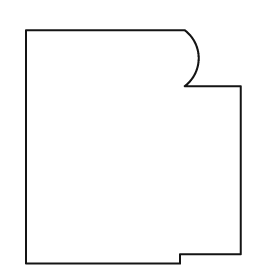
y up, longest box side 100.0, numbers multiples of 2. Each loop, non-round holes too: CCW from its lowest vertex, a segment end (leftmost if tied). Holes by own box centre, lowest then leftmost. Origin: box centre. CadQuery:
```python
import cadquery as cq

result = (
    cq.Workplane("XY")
    .moveTo(-46.0, -50.0)
    .lineTo(20.0, -50.0)
    .lineTo(20.0, -46.0)
    .lineTo(46.0, -46.0)
    .lineTo(46.0, 26.0)
    .lineTo(22.0, 26.0)
    .threePointArc((28.0, 38.0), (22.0, 50.0))
    .lineTo(-46.0, 50.0)
    .close()
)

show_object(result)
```